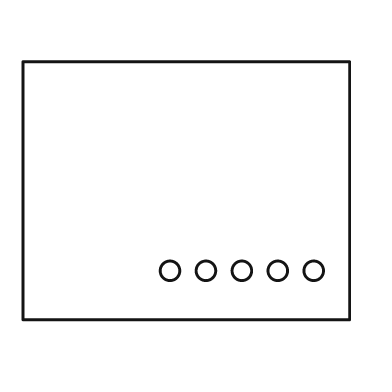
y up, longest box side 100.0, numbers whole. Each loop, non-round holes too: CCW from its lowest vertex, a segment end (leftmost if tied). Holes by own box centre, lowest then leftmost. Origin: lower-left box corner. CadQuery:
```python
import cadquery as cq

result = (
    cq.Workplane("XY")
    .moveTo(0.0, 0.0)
    .lineTo(100.0, 0.0)
    .lineTo(100.0, 79.0)
    .lineTo(0.0, 79.0)
    .close()
    .moveTo(45.0, 15.0)
    .circle(3.0)
    .moveTo(56.0, 15.0)
    .circle(3.0)
    .moveTo(67.0, 15.0)
    .circle(3.0)
    .moveTo(78.0, 15.0)
    .circle(3.0)
    .moveTo(89.0, 15.0)
    .circle(3.0)
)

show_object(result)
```